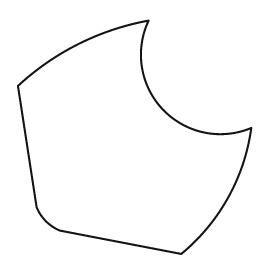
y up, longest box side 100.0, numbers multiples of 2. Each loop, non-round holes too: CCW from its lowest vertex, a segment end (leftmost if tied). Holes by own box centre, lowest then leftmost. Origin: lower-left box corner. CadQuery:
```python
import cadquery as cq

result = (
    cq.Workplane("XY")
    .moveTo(70.0, 0.0)
    .threePointArc((90.0, 24.0), (100.0, 54.0))
    .threePointArc((62.0, 62.0), (56.0, 100.0))
    .threePointArc((26.0, 90.0), (0.0, 72.0))
    .lineTo(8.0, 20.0)
    .threePointArc((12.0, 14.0), (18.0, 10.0))
    .close()
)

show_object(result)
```